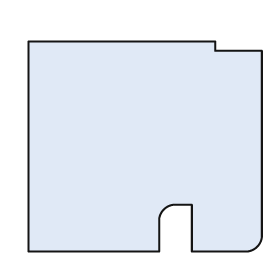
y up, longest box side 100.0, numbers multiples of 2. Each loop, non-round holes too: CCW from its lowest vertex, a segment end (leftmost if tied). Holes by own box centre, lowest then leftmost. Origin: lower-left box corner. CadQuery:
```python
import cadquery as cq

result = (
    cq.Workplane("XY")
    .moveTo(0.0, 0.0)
    .lineTo(56.0, 0.0)
    .lineTo(56.0, 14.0)
    .threePointArc((58.0, 18.0), (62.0, 20.0))
    .lineTo(70.0, 20.0)
    .lineTo(70.0, 0.0)
    .lineTo(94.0, 0.0)
    .threePointArc((98.0, 2.0), (100.0, 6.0))
    .lineTo(100.0, 86.0)
    .lineTo(80.0, 86.0)
    .lineTo(80.0, 90.0)
    .lineTo(0.0, 90.0)
    .close()
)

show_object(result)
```